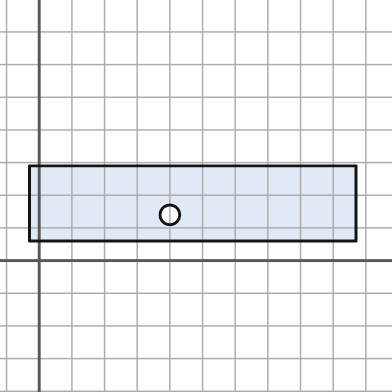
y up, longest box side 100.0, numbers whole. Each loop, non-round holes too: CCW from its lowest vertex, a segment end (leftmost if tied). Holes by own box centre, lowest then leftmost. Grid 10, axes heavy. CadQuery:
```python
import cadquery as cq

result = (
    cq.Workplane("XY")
    .moveTo(-3.0, 6.0)
    .lineTo(97.0, 6.0)
    .lineTo(97.0, 29.0)
    .lineTo(-3.0, 29.0)
    .close()
    .moveTo(40.0, 14.0)
    .circle(3.0)
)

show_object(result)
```